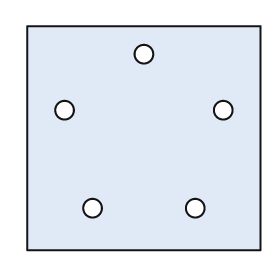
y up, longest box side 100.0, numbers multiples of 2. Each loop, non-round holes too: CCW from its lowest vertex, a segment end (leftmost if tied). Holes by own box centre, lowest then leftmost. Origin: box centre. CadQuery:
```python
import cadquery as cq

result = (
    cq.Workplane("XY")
    .moveTo(-50.0, -48.0)
    .lineTo(50.0, -48.0)
    .lineTo(50.0, 48.0)
    .lineTo(-50.0, 48.0)
    .close()
    .moveTo(-22.0, -30.0)
    .circle(4.0)
    .moveTo(22.0, -30.0)
    .circle(4.0)
    .moveTo(-34.0, 12.0)
    .circle(4.0)
    .moveTo(34.0, 12.0)
    .circle(4.0)
    .moveTo(0.0, 36.0)
    .circle(4.0)
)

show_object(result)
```